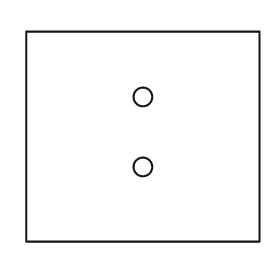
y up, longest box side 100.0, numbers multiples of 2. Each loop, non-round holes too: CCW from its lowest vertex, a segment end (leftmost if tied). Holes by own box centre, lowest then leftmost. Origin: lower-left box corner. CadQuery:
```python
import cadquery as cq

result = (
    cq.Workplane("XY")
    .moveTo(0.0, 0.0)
    .lineTo(100.0, 0.0)
    .lineTo(100.0, 90.0)
    .lineTo(0.0, 90.0)
    .close()
    .moveTo(50.0, 32.0)
    .circle(4.0)
    .moveTo(50.0, 62.0)
    .circle(4.0)
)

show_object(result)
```